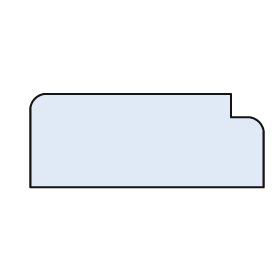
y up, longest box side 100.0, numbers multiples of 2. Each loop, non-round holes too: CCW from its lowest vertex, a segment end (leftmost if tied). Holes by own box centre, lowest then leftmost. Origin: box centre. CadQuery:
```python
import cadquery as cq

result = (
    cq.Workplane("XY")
    .moveTo(-50.0, -20.0)
    .lineTo(50.0, -20.0)
    .lineTo(50.0, 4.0)
    .threePointArc((48.0, 8.0), (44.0, 10.0))
    .lineTo(36.0, 10.0)
    .lineTo(36.0, 20.0)
    .lineTo(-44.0, 20.0)
    .threePointArc((-48.0, 18.0), (-50.0, 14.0))
    .close()
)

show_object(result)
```